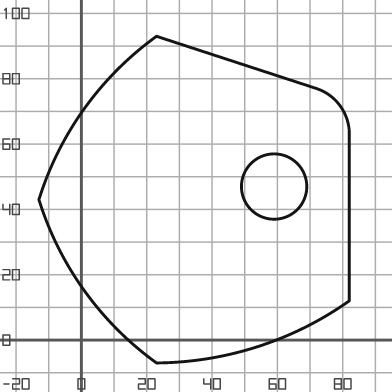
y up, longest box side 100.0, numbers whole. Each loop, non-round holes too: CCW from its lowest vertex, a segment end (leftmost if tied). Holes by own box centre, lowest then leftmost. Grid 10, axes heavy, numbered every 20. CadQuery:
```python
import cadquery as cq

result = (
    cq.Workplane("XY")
    .moveTo(23.0, -7.0)
    .threePointArc((54.0, -2.0), (82.0, 12.0))
    .lineTo(82.0, 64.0)
    .threePointArc((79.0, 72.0), (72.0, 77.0))
    .lineTo(23.0, 93.0)
    .threePointArc((1.0, 71.0), (-13.0, 43.0))
    .threePointArc((1.0, 15.0), (23.0, -7.0))
    .close()
    .moveTo(59.0, 47.0)
    .circle(10.0)
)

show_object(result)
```